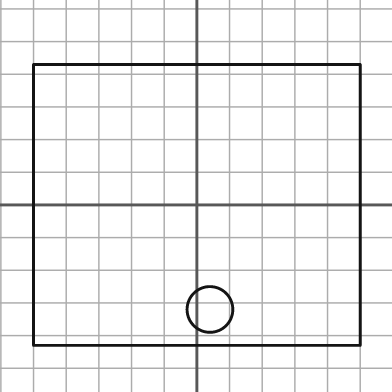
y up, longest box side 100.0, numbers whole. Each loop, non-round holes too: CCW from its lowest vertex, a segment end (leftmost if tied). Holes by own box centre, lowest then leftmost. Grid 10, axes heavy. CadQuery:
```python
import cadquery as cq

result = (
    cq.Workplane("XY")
    .moveTo(-50.0, -43.0)
    .lineTo(50.0, -43.0)
    .lineTo(50.0, 43.0)
    .lineTo(-50.0, 43.0)
    .close()
    .moveTo(4.0, -32.0)
    .circle(7.0)
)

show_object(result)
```